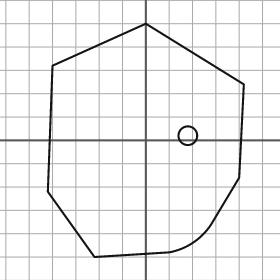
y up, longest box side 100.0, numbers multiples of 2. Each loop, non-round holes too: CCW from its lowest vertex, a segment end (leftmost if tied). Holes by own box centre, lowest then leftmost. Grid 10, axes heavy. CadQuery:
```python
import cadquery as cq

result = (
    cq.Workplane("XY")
    .moveTo(-22.0, -50.0)
    .lineTo(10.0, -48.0)
    .threePointArc((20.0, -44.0), (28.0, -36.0))
    .lineTo(40.0, -16.0)
    .lineTo(42.0, 24.0)
    .lineTo(0.0, 50.0)
    .lineTo(-40.0, 32.0)
    .lineTo(-42.0, -22.0)
    .close()
    .moveTo(18.0, 2.0)
    .circle(4.0)
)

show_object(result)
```